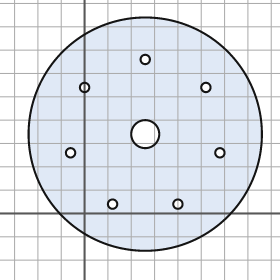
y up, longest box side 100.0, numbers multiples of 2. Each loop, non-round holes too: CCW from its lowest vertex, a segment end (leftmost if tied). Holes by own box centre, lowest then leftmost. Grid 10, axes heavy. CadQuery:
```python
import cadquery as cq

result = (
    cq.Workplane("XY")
    .moveTo(26.0, 34.0)
    .circle(50.0)
    .moveTo(12.0, 4.0)
    .circle(2.0)
    .moveTo(40.0, 4.0)
    .circle(2.0)
    .moveTo(-6.0, 26.0)
    .circle(2.0)
    .moveTo(58.0, 26.0)
    .circle(2.0)
    .moveTo(26.0, 34.0)
    .circle(6.0)
    .moveTo(0.0, 54.0)
    .circle(2.0)
    .moveTo(52.0, 54.0)
    .circle(2.0)
    .moveTo(26.0, 66.0)
    .circle(2.0)
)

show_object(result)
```